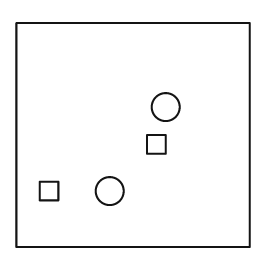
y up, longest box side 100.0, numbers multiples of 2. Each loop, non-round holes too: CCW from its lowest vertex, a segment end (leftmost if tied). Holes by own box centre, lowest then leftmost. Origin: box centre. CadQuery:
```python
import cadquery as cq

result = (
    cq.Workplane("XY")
    .moveTo(-50.0, -48.0)
    .lineTo(50.0, -48.0)
    .lineTo(50.0, 48.0)
    .lineTo(-50.0, 48.0)
    .close()
    .moveTo(-40.0, -28.0)
    .lineTo(-32.0, -28.0)
    .lineTo(-32.0, -20.0)
    .lineTo(-40.0, -20.0)
    .close()
    .moveTo(-10.0, -24.0)
    .circle(6.0)
    .moveTo(6.0, -8.0)
    .lineTo(14.0, -8.0)
    .lineTo(14.0, 0.0)
    .lineTo(6.0, 0.0)
    .close()
    .moveTo(14.0, 12.0)
    .circle(6.0)
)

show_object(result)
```